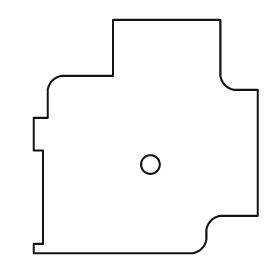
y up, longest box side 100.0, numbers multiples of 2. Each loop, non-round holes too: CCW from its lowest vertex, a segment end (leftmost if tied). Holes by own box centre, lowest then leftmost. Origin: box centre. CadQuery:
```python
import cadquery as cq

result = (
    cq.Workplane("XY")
    .moveTo(-48.0, -50.0)
    .lineTo(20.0, -50.0)
    .threePointArc((24.0, -48.0), (26.0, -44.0))
    .lineTo(26.0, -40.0)
    .threePointArc((28.0, -36.0), (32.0, -34.0))
    .lineTo(48.0, -34.0)
    .lineTo(48.0, 20.0)
    .lineTo(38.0, 20.0)
    .threePointArc((34.0, 22.0), (32.0, 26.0))
    .lineTo(32.0, 50.0)
    .lineTo(-14.0, 50.0)
    .lineTo(-14.0, 26.0)
    .lineTo(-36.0, 26.0)
    .threePointArc((-40.0, 24.0), (-42.0, 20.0))
    .lineTo(-42.0, 8.0)
    .lineTo(-48.0, 8.0)
    .lineTo(-48.0, -6.0)
    .lineTo(-44.0, -6.0)
    .lineTo(-44.0, -46.0)
    .lineTo(-48.0, -46.0)
    .close()
    .moveTo(2.0, -12.0)
    .circle(4.0)
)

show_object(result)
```